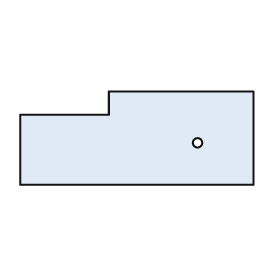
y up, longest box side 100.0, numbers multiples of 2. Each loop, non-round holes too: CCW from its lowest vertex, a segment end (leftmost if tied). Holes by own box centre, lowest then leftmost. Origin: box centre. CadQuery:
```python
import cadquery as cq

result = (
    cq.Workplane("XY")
    .moveTo(-50.0, -20.0)
    .lineTo(50.0, -20.0)
    .lineTo(50.0, 20.0)
    .lineTo(-12.0, 20.0)
    .lineTo(-12.0, 10.0)
    .lineTo(-50.0, 10.0)
    .close()
    .moveTo(26.0, -2.0)
    .circle(2.0)
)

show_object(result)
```